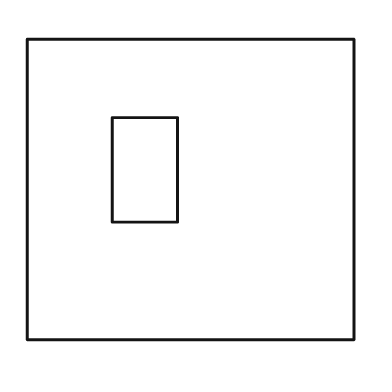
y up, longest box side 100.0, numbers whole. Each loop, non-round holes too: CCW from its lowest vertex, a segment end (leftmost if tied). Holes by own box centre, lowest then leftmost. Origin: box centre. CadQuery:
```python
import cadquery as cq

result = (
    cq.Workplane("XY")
    .moveTo(-50.0, -46.0)
    .lineTo(50.0, -46.0)
    .lineTo(50.0, 46.0)
    .lineTo(-50.0, 46.0)
    .close()
    .moveTo(-24.0, -10.0)
    .lineTo(-4.0, -10.0)
    .lineTo(-4.0, 22.0)
    .lineTo(-24.0, 22.0)
    .close()
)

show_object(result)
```